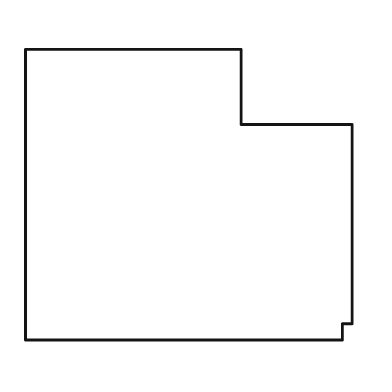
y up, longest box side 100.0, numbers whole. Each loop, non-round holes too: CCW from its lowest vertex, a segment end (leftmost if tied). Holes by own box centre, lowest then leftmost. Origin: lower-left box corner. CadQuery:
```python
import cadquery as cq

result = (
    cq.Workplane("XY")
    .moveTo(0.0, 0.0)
    .lineTo(97.0, 0.0)
    .lineTo(97.0, 5.0)
    .lineTo(100.0, 5.0)
    .lineTo(100.0, 66.0)
    .lineTo(66.0, 66.0)
    .lineTo(66.0, 89.0)
    .lineTo(0.0, 89.0)
    .close()
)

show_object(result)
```